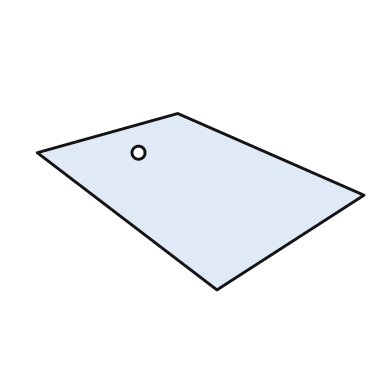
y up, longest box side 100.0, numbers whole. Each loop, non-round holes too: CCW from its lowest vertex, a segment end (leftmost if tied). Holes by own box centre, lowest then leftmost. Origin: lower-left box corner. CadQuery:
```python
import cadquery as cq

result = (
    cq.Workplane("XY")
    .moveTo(55.0, 0.0)
    .lineTo(100.0, 29.0)
    .lineTo(43.0, 54.0)
    .lineTo(0.0, 42.0)
    .close()
    .moveTo(31.0, 42.0)
    .circle(2.0)
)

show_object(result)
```